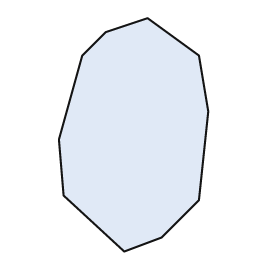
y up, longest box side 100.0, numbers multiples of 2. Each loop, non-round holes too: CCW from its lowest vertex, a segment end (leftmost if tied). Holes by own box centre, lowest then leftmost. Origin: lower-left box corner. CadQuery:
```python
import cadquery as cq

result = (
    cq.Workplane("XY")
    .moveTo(28.0, 0.0)
    .lineTo(44.0, 6.0)
    .lineTo(60.0, 22.0)
    .lineTo(64.0, 60.0)
    .lineTo(60.0, 84.0)
    .lineTo(38.0, 100.0)
    .lineTo(20.0, 94.0)
    .lineTo(10.0, 84.0)
    .lineTo(0.0, 48.0)
    .lineTo(2.0, 24.0)
    .close()
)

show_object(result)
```